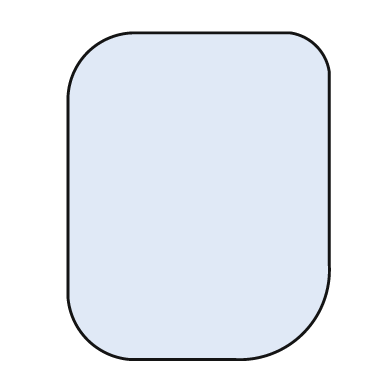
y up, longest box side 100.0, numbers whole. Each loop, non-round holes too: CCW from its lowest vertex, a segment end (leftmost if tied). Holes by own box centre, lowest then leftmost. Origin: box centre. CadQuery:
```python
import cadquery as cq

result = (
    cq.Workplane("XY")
    .moveTo(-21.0, -50.0)
    .lineTo(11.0, -50.0)
    .threePointArc((32.0, -42.0), (40.0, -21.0))
    .lineTo(40.0, 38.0)
    .threePointArc((36.0, 46.0), (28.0, 50.0))
    .lineTo(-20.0, 50.0)
    .threePointArc((-34.0, 44.0), (-40.0, 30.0))
    .lineTo(-40.0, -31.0)
    .threePointArc((-34.0, -44.0), (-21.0, -50.0))
    .close()
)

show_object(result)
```